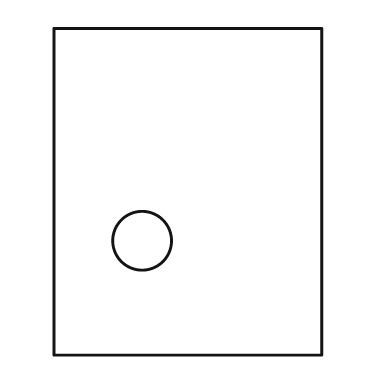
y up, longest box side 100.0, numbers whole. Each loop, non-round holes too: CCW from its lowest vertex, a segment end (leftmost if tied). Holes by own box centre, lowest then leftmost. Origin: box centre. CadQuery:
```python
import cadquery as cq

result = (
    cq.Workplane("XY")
    .moveTo(-41.0, -50.0)
    .lineTo(41.0, -50.0)
    .lineTo(41.0, 50.0)
    .lineTo(-41.0, 50.0)
    .close()
    .moveTo(-14.0, -15.0)
    .circle(9.0)
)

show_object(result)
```